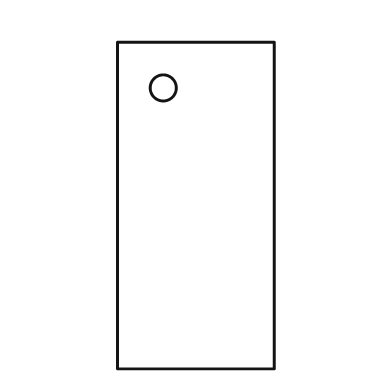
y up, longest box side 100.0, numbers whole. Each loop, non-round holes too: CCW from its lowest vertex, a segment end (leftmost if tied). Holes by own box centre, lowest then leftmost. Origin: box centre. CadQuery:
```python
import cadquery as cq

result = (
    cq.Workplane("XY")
    .moveTo(-24.0, -50.0)
    .lineTo(24.0, -50.0)
    .lineTo(24.0, 50.0)
    .lineTo(-24.0, 50.0)
    .close()
    .moveTo(-10.0, 36.0)
    .circle(4.0)
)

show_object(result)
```